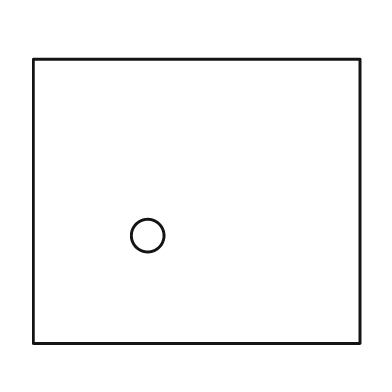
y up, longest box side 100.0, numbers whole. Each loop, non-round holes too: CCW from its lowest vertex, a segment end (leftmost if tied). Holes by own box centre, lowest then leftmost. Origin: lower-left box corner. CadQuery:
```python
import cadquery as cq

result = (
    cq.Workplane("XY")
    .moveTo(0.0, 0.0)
    .lineTo(100.0, 0.0)
    .lineTo(100.0, 87.0)
    .lineTo(0.0, 87.0)
    .close()
    .moveTo(35.0, 33.0)
    .circle(5.0)
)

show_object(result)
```